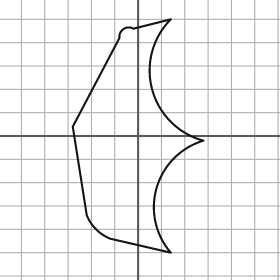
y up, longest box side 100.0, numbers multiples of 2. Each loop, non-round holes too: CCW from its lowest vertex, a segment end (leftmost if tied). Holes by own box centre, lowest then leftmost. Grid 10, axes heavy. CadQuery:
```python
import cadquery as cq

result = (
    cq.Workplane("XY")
    .moveTo(14.0, -50.0)
    .threePointArc((8.0, -22.0), (28.0, -2.0))
    .threePointArc((6.0, 20.0), (14.0, 50.0))
    .lineTo(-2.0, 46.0)
    .threePointArc((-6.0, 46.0), (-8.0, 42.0))
    .lineTo(-28.0, 4.0)
    .lineTo(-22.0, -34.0)
    .threePointArc((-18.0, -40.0), (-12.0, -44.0))
    .close()
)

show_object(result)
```